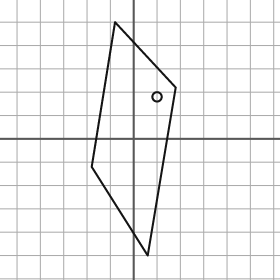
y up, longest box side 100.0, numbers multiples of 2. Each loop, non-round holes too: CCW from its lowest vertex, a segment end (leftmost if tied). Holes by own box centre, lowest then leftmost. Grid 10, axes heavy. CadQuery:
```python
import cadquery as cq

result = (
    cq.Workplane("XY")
    .moveTo(6.0, -50.0)
    .lineTo(18.0, 22.0)
    .lineTo(-8.0, 50.0)
    .lineTo(-18.0, -12.0)
    .close()
    .moveTo(10.0, 18.0)
    .circle(2.0)
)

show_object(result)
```